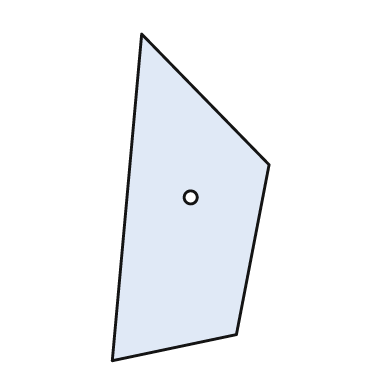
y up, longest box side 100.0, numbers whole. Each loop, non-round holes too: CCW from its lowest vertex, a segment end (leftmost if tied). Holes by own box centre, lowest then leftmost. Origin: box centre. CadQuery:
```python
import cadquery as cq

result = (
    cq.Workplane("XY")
    .moveTo(-24.0, -50.0)
    .lineTo(14.0, -42.0)
    .lineTo(24.0, 10.0)
    .lineTo(-15.0, 50.0)
    .close()
    .moveTo(0.0, 0.0)
    .circle(2.0)
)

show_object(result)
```